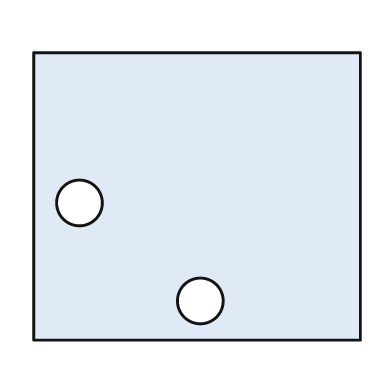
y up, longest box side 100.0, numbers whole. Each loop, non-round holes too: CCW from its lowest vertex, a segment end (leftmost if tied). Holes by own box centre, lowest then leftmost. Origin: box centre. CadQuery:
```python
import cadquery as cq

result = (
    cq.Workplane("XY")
    .moveTo(-50.0, -44.0)
    .lineTo(50.0, -44.0)
    .lineTo(50.0, 44.0)
    .lineTo(-50.0, 44.0)
    .close()
    .moveTo(1.0, -32.0)
    .circle(7.0)
    .moveTo(-36.0, -2.0)
    .circle(7.0)
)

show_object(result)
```